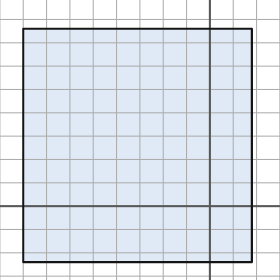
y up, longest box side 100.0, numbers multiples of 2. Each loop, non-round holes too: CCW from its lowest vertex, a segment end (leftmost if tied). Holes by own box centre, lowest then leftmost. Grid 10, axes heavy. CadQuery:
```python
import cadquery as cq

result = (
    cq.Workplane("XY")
    .moveTo(-80.0, -24.0)
    .lineTo(18.0, -24.0)
    .lineTo(18.0, 76.0)
    .lineTo(-80.0, 76.0)
    .close()
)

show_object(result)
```